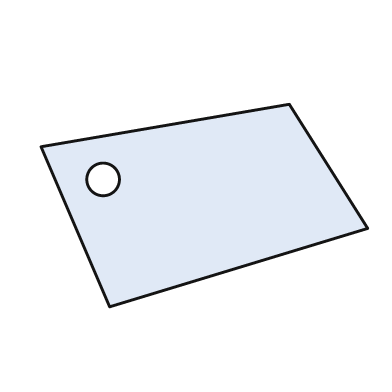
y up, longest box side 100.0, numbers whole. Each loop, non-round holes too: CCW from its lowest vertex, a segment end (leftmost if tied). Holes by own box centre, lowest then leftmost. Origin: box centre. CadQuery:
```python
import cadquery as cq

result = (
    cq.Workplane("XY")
    .moveTo(-29.0, -31.0)
    .lineTo(50.0, -7.0)
    .lineTo(26.0, 31.0)
    .lineTo(-50.0, 18.0)
    .close()
    .moveTo(-31.0, 8.0)
    .circle(5.0)
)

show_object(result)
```